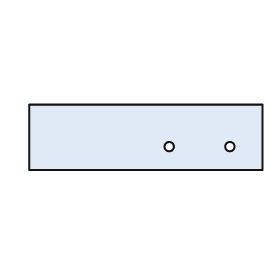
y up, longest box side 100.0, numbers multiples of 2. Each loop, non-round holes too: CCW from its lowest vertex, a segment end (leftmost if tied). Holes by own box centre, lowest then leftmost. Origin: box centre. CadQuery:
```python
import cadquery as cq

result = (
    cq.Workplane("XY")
    .moveTo(-50.0, -14.0)
    .lineTo(50.0, -14.0)
    .lineTo(50.0, 14.0)
    .lineTo(-50.0, 14.0)
    .close()
    .moveTo(10.0, -4.0)
    .circle(2.0)
    .moveTo(36.0, -4.0)
    .circle(2.0)
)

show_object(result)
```